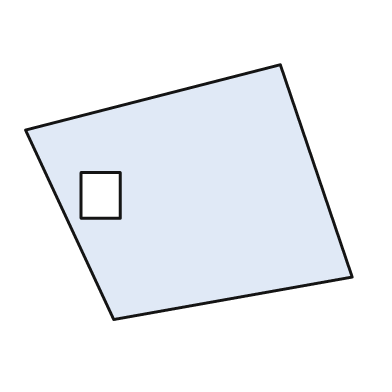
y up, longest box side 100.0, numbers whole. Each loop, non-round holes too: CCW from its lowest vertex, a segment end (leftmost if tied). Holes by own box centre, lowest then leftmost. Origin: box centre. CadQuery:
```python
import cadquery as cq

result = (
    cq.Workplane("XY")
    .moveTo(-23.0, -39.0)
    .lineTo(50.0, -26.0)
    .lineTo(28.0, 39.0)
    .lineTo(-50.0, 19.0)
    .close()
    .moveTo(-33.0, -8.0)
    .lineTo(-21.0, -8.0)
    .lineTo(-21.0, 6.0)
    .lineTo(-33.0, 6.0)
    .close()
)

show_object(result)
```